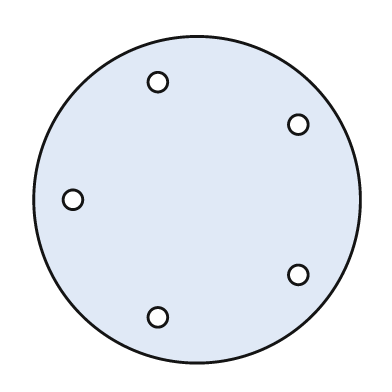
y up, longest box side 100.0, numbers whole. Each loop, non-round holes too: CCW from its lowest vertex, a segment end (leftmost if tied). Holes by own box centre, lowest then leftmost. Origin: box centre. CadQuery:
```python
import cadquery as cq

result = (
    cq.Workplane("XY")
    .moveTo(0.0, 0.0)
    .circle(50.0)
    .moveTo(-12.0, -36.0)
    .circle(3.0)
    .moveTo(31.0, -23.0)
    .circle(3.0)
    .moveTo(-38.0, 0.0)
    .circle(3.0)
    .moveTo(31.0, 23.0)
    .circle(3.0)
    .moveTo(-12.0, 36.0)
    .circle(3.0)
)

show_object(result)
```